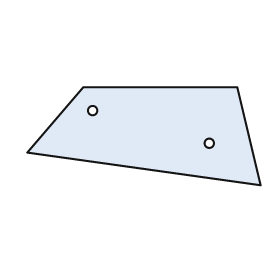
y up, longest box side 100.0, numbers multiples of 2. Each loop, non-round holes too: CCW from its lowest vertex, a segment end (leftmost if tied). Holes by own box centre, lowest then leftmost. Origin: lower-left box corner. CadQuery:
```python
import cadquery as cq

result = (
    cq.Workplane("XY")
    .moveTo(100.0, 0.0)
    .lineTo(90.0, 42.0)
    .lineTo(24.0, 42.0)
    .lineTo(0.0, 14.0)
    .close()
    .moveTo(78.0, 18.0)
    .circle(2.0)
    .moveTo(28.0, 32.0)
    .circle(2.0)
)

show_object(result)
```